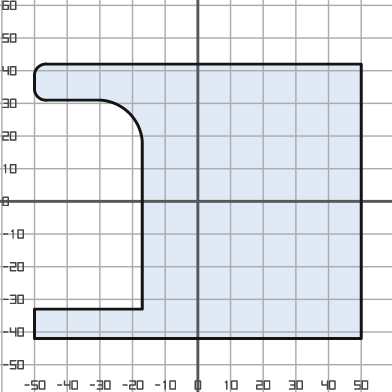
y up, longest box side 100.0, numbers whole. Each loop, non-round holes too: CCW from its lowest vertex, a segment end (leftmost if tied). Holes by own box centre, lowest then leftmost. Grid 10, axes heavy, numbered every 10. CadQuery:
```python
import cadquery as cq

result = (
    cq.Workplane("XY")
    .moveTo(-50.0, -42.0)
    .lineTo(50.0, -42.0)
    .lineTo(50.0, 42.0)
    .lineTo(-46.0, 42.0)
    .threePointArc((-49.0, 41.0), (-50.0, 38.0))
    .lineTo(-50.0, 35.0)
    .threePointArc((-49.0, 32.0), (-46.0, 31.0))
    .lineTo(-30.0, 31.0)
    .threePointArc((-21.0, 27.0), (-17.0, 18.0))
    .lineTo(-17.0, -33.0)
    .lineTo(-50.0, -33.0)
    .close()
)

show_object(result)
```